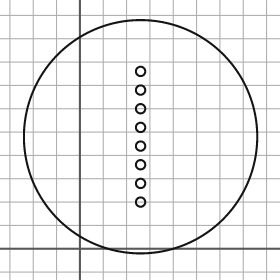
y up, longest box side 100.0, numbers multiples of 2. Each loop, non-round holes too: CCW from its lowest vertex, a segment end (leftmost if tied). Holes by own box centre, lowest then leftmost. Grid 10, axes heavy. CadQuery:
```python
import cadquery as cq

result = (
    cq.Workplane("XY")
    .moveTo(26.0, 48.0)
    .circle(50.0)
    .moveTo(26.0, 20.0)
    .circle(2.0)
    .moveTo(26.0, 28.0)
    .circle(2.0)
    .moveTo(26.0, 36.0)
    .circle(2.0)
    .moveTo(26.0, 44.0)
    .circle(2.0)
    .moveTo(26.0, 52.0)
    .circle(2.0)
    .moveTo(26.0, 60.0)
    .circle(2.0)
    .moveTo(26.0, 68.0)
    .circle(2.0)
    .moveTo(26.0, 76.0)
    .circle(2.0)
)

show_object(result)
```